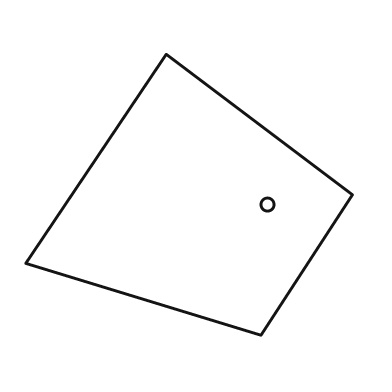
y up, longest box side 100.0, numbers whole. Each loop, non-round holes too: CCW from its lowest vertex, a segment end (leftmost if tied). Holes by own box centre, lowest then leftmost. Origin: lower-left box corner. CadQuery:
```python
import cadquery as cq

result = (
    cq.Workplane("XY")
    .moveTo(72.0, 0.0)
    .lineTo(100.0, 43.0)
    .lineTo(43.0, 86.0)
    .lineTo(0.0, 22.0)
    .close()
    .moveTo(74.0, 40.0)
    .circle(2.0)
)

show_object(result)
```